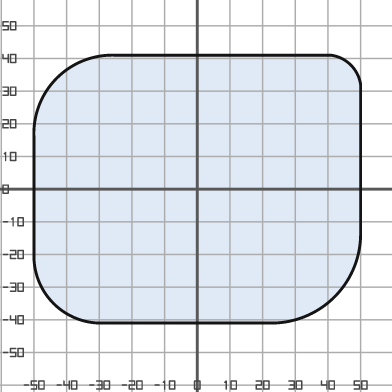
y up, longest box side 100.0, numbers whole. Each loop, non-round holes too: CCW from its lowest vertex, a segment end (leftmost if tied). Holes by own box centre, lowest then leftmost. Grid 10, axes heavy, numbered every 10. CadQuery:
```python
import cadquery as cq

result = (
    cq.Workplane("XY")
    .moveTo(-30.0, -41.0)
    .lineTo(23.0, -41.0)
    .threePointArc((42.0, -33.0), (50.0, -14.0))
    .lineTo(50.0, 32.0)
    .threePointArc((47.0, 38.0), (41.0, 41.0))
    .lineTo(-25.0, 41.0)
    .threePointArc((-43.0, 34.0), (-50.0, 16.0))
    .lineTo(-50.0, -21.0)
    .threePointArc((-44.0, -35.0), (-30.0, -41.0))
    .close()
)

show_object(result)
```